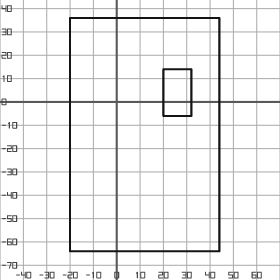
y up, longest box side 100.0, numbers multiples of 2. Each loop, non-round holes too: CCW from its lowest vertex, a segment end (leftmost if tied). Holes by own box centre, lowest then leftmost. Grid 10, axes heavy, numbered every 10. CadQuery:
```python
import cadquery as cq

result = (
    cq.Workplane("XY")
    .moveTo(-20.0, -64.0)
    .lineTo(44.0, -64.0)
    .lineTo(44.0, 36.0)
    .lineTo(-20.0, 36.0)
    .close()
    .moveTo(20.0, -6.0)
    .lineTo(32.0, -6.0)
    .lineTo(32.0, 14.0)
    .lineTo(20.0, 14.0)
    .close()
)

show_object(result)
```